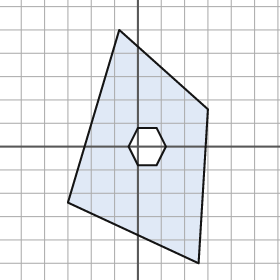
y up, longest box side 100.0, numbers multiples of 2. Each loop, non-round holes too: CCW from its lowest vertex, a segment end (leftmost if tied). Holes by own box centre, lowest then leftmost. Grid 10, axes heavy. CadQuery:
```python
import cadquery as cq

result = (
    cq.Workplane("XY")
    .moveTo(26.0, -50.0)
    .lineTo(30.0, 16.0)
    .lineTo(-8.0, 50.0)
    .lineTo(-30.0, -24.0)
    .close()
    .moveTo(0.0, -8.0)
    .lineTo(8.0, -8.0)
    .lineTo(12.0, 0.0)
    .lineTo(8.0, 8.0)
    .lineTo(0.0, 8.0)
    .lineTo(-4.0, 0.0)
    .close()
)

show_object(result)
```